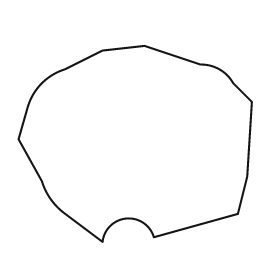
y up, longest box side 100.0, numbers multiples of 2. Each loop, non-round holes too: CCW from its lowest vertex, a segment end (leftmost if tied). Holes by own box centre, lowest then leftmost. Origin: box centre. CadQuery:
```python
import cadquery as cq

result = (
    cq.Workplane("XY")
    .moveTo(-14.0, -42.0)
    .threePointArc((-4.0, -32.0), (8.0, -40.0))
    .lineTo(44.0, -30.0)
    .lineTo(48.0, -14.0)
    .lineTo(50.0, 18.0)
    .lineTo(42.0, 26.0)
    .threePointArc((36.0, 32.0), (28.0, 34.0))
    .lineTo(4.0, 42.0)
    .lineTo(-14.0, 40.0)
    .lineTo(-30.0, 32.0)
    .threePointArc((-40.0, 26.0), (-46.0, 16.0))
    .lineTo(-50.0, 2.0)
    .lineTo(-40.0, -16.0)
    .threePointArc((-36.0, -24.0), (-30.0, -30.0))
    .close()
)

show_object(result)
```